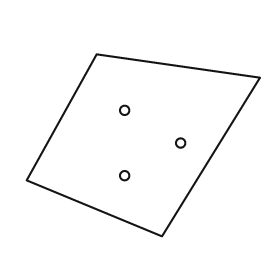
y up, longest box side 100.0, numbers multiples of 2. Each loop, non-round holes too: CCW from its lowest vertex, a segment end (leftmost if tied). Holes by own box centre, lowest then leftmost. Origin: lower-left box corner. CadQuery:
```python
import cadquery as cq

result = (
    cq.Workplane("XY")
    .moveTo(58.0, 0.0)
    .lineTo(100.0, 68.0)
    .lineTo(30.0, 78.0)
    .lineTo(0.0, 24.0)
    .close()
    .moveTo(42.0, 26.0)
    .circle(2.0)
    .moveTo(66.0, 40.0)
    .circle(2.0)
    .moveTo(42.0, 54.0)
    .circle(2.0)
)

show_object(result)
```